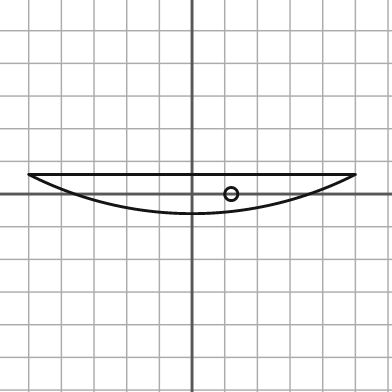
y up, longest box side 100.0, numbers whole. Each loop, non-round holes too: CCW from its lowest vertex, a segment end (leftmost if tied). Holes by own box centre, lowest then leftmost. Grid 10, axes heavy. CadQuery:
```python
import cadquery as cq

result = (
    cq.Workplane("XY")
    .moveTo(-50.0, 6.0)
    .threePointArc((0.0, -6.0), (50.0, 6.0))
    .close()
    .moveTo(12.0, 0.0)
    .circle(2.0)
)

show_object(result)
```